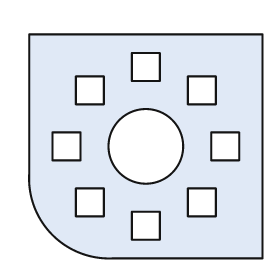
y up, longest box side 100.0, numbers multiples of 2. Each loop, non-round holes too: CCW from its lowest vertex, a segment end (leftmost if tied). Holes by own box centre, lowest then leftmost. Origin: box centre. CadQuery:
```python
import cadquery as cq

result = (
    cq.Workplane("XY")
    .moveTo(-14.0, -48.0)
    .lineTo(50.0, -48.0)
    .lineTo(50.0, 48.0)
    .lineTo(-50.0, 48.0)
    .lineTo(-50.0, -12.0)
    .threePointArc((-40.0, -38.0), (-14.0, -48.0))
    .close()
    .moveTo(-6.0, -40.0)
    .lineTo(6.0, -40.0)
    .lineTo(6.0, -28.0)
    .lineTo(-6.0, -28.0)
    .close()
    .moveTo(-30.0, -30.0)
    .lineTo(-18.0, -30.0)
    .lineTo(-18.0, -18.0)
    .lineTo(-30.0, -18.0)
    .close()
    .moveTo(18.0, -30.0)
    .lineTo(30.0, -30.0)
    .lineTo(30.0, -18.0)
    .lineTo(18.0, -18.0)
    .close()
    .moveTo(-40.0, -6.0)
    .lineTo(-28.0, -6.0)
    .lineTo(-28.0, 6.0)
    .lineTo(-40.0, 6.0)
    .close()
    .moveTo(0.0, 0.0)
    .circle(16.0)
    .moveTo(28.0, -6.0)
    .lineTo(40.0, -6.0)
    .lineTo(40.0, 6.0)
    .lineTo(28.0, 6.0)
    .close()
    .moveTo(-30.0, 18.0)
    .lineTo(-18.0, 18.0)
    .lineTo(-18.0, 30.0)
    .lineTo(-30.0, 30.0)
    .close()
    .moveTo(18.0, 18.0)
    .lineTo(30.0, 18.0)
    .lineTo(30.0, 30.0)
    .lineTo(18.0, 30.0)
    .close()
    .moveTo(-6.0, 28.0)
    .lineTo(6.0, 28.0)
    .lineTo(6.0, 40.0)
    .lineTo(-6.0, 40.0)
    .close()
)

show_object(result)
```